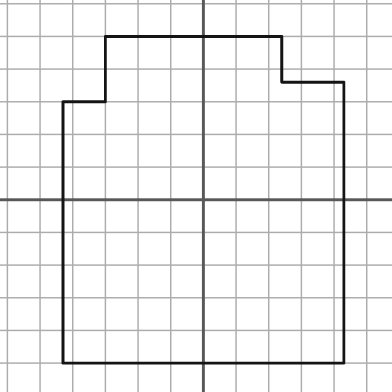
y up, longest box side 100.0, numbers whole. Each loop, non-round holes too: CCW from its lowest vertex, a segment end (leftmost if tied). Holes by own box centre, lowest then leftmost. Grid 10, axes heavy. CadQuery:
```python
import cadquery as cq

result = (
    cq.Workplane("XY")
    .moveTo(-43.0, -50.0)
    .lineTo(43.0, -50.0)
    .lineTo(43.0, 36.0)
    .lineTo(24.0, 36.0)
    .lineTo(24.0, 50.0)
    .lineTo(-30.0, 50.0)
    .lineTo(-30.0, 30.0)
    .lineTo(-43.0, 30.0)
    .close()
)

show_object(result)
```